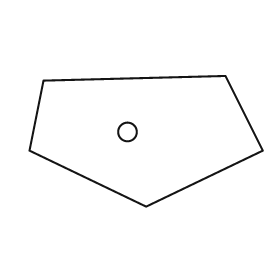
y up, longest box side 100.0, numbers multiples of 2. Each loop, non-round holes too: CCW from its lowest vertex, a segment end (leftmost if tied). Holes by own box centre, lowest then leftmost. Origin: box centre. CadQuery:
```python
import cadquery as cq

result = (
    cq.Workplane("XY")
    .moveTo(0.0, -28.0)
    .lineTo(50.0, -4.0)
    .lineTo(34.0, 28.0)
    .lineTo(-44.0, 26.0)
    .lineTo(-50.0, -4.0)
    .close()
    .moveTo(-8.0, 4.0)
    .circle(4.0)
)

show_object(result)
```